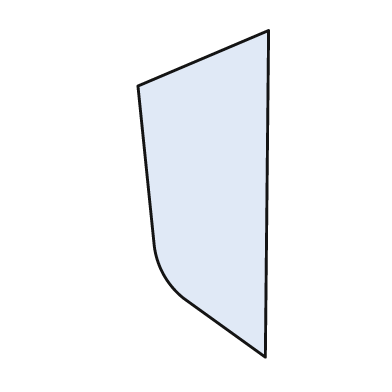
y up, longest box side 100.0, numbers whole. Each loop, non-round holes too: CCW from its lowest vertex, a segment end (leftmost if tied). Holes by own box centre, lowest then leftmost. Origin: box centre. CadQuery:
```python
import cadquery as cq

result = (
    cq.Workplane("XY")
    .moveTo(19.0, -50.0)
    .lineTo(20.0, 50.0)
    .lineTo(-20.0, 33.0)
    .lineTo(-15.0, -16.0)
    .threePointArc((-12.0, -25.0), (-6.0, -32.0))
    .close()
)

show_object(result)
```